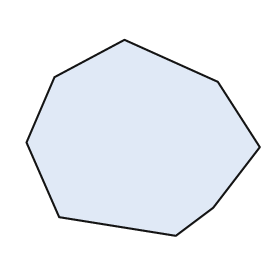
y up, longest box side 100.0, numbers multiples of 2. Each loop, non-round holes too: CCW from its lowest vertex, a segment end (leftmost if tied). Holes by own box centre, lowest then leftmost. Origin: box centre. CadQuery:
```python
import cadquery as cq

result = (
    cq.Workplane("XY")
    .moveTo(14.0, -42.0)
    .lineTo(30.0, -30.0)
    .lineTo(50.0, -4.0)
    .lineTo(32.0, 24.0)
    .lineTo(-8.0, 42.0)
    .lineTo(-38.0, 26.0)
    .lineTo(-50.0, -2.0)
    .lineTo(-36.0, -34.0)
    .close()
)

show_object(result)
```